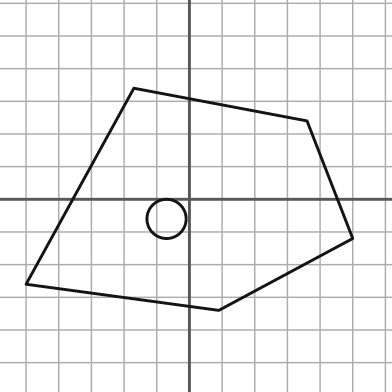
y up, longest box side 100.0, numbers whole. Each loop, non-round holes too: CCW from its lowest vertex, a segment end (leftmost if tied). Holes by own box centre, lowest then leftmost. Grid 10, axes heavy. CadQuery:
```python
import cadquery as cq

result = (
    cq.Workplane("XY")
    .moveTo(9.0, -34.0)
    .lineTo(50.0, -12.0)
    .lineTo(36.0, 24.0)
    .lineTo(-17.0, 34.0)
    .lineTo(-50.0, -26.0)
    .close()
    .moveTo(-7.0, -6.0)
    .circle(6.0)
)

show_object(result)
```